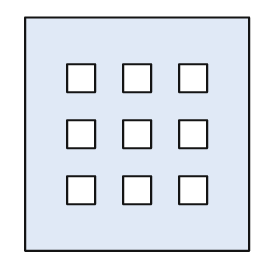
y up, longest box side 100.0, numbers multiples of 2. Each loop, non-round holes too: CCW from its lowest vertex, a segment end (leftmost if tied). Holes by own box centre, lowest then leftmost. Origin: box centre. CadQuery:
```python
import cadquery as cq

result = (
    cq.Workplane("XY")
    .moveTo(-48.0, -50.0)
    .lineTo(48.0, -50.0)
    .lineTo(48.0, 50.0)
    .lineTo(-48.0, 50.0)
    .close()
    .moveTo(-30.0, -30.0)
    .lineTo(-18.0, -30.0)
    .lineTo(-18.0, -18.0)
    .lineTo(-30.0, -18.0)
    .close()
    .moveTo(-6.0, -30.0)
    .lineTo(6.0, -30.0)
    .lineTo(6.0, -18.0)
    .lineTo(-6.0, -18.0)
    .close()
    .moveTo(18.0, -30.0)
    .lineTo(30.0, -30.0)
    .lineTo(30.0, -18.0)
    .lineTo(18.0, -18.0)
    .close()
    .moveTo(-30.0, -6.0)
    .lineTo(-18.0, -6.0)
    .lineTo(-18.0, 6.0)
    .lineTo(-30.0, 6.0)
    .close()
    .moveTo(-6.0, -6.0)
    .lineTo(6.0, -6.0)
    .lineTo(6.0, 6.0)
    .lineTo(-6.0, 6.0)
    .close()
    .moveTo(18.0, -6.0)
    .lineTo(30.0, -6.0)
    .lineTo(30.0, 6.0)
    .lineTo(18.0, 6.0)
    .close()
    .moveTo(-30.0, 18.0)
    .lineTo(-18.0, 18.0)
    .lineTo(-18.0, 30.0)
    .lineTo(-30.0, 30.0)
    .close()
    .moveTo(-6.0, 18.0)
    .lineTo(6.0, 18.0)
    .lineTo(6.0, 30.0)
    .lineTo(-6.0, 30.0)
    .close()
    .moveTo(18.0, 18.0)
    .lineTo(30.0, 18.0)
    .lineTo(30.0, 30.0)
    .lineTo(18.0, 30.0)
    .close()
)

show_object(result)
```